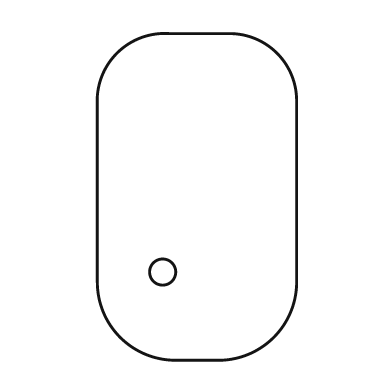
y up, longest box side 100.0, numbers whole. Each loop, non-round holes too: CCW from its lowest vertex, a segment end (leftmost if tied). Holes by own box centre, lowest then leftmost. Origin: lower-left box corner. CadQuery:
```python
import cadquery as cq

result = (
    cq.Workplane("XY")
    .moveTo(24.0, 0.0)
    .lineTo(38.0, 0.0)
    .threePointArc((54.0, 7.0), (61.0, 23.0))
    .lineTo(61.0, 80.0)
    .threePointArc((55.0, 94.0), (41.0, 100.0))
    .lineTo(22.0, 100.0)
    .threePointArc((6.0, 94.0), (0.0, 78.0))
    .lineTo(0.0, 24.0)
    .threePointArc((7.0, 7.0), (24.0, 0.0))
    .close()
    .moveTo(20.0, 27.0)
    .circle(4.0)
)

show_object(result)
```